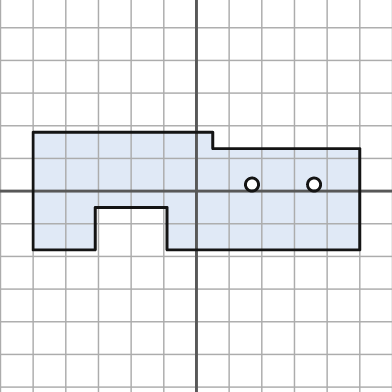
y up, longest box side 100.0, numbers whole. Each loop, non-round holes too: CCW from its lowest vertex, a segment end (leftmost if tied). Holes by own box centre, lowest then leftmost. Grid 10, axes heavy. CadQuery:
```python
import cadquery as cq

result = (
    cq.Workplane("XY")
    .moveTo(-50.0, -18.0)
    .lineTo(-31.0, -18.0)
    .lineTo(-31.0, -5.0)
    .lineTo(-9.0, -5.0)
    .lineTo(-9.0, -18.0)
    .lineTo(50.0, -18.0)
    .lineTo(50.0, 13.0)
    .lineTo(5.0, 13.0)
    .lineTo(5.0, 18.0)
    .lineTo(-50.0, 18.0)
    .close()
    .moveTo(17.0, 2.0)
    .circle(2.0)
    .moveTo(36.0, 2.0)
    .circle(2.0)
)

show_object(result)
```